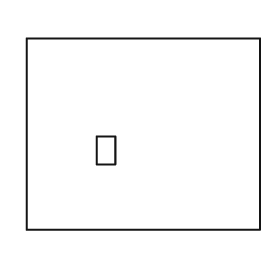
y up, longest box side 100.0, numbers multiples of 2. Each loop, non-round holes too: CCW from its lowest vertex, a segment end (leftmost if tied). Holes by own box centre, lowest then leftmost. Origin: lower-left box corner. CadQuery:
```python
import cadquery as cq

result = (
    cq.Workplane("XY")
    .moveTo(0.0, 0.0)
    .lineTo(100.0, 0.0)
    .lineTo(100.0, 82.0)
    .lineTo(0.0, 82.0)
    .close()
    .moveTo(30.0, 28.0)
    .lineTo(38.0, 28.0)
    .lineTo(38.0, 40.0)
    .lineTo(30.0, 40.0)
    .close()
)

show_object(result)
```